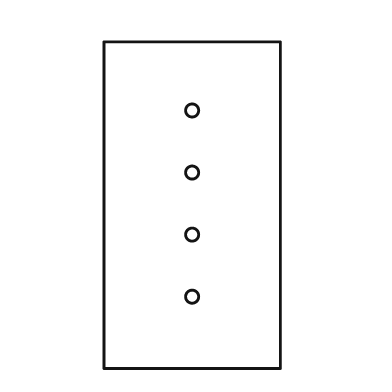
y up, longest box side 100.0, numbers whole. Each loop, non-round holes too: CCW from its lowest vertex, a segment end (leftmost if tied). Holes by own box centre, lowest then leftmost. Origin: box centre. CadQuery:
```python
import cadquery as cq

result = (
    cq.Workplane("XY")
    .moveTo(-27.0, -50.0)
    .lineTo(27.0, -50.0)
    .lineTo(27.0, 50.0)
    .lineTo(-27.0, 50.0)
    .close()
    .moveTo(0.0, -28.0)
    .circle(2.0)
    .moveTo(0.0, -9.0)
    .circle(2.0)
    .moveTo(0.0, 10.0)
    .circle(2.0)
    .moveTo(0.0, 29.0)
    .circle(2.0)
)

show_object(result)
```